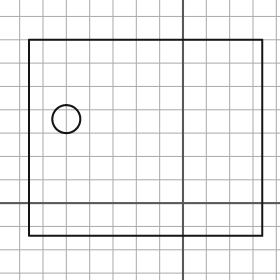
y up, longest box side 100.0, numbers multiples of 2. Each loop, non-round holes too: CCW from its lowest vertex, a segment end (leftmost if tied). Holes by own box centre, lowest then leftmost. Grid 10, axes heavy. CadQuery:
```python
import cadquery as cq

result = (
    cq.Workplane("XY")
    .moveTo(-66.0, -14.0)
    .lineTo(34.0, -14.0)
    .lineTo(34.0, 70.0)
    .lineTo(-66.0, 70.0)
    .close()
    .moveTo(-50.0, 36.0)
    .circle(6.0)
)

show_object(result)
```